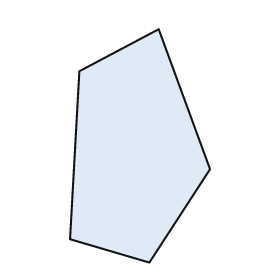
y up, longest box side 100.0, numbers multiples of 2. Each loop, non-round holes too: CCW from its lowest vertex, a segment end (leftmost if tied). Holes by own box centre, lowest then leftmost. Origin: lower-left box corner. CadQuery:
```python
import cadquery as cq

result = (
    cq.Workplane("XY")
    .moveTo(34.0, 0.0)
    .lineTo(60.0, 40.0)
    .lineTo(38.0, 100.0)
    .lineTo(4.0, 82.0)
    .lineTo(0.0, 10.0)
    .close()
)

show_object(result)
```